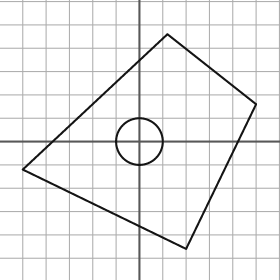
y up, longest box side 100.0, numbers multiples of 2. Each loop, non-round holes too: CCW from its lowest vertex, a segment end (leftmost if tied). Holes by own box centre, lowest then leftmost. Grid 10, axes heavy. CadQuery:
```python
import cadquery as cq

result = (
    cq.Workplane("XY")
    .moveTo(20.0, -46.0)
    .lineTo(50.0, 16.0)
    .lineTo(12.0, 46.0)
    .lineTo(-50.0, -12.0)
    .close()
    .moveTo(0.0, 0.0)
    .circle(10.0)
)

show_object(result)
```